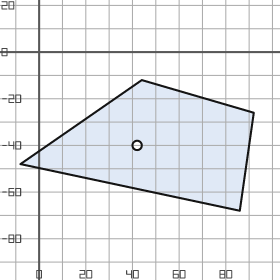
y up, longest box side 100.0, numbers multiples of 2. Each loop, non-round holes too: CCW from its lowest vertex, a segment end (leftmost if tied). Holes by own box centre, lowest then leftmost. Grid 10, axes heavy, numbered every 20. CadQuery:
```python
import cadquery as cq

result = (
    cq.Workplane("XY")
    .moveTo(86.0, -68.0)
    .lineTo(92.0, -26.0)
    .lineTo(44.0, -12.0)
    .lineTo(-8.0, -48.0)
    .close()
    .moveTo(42.0, -40.0)
    .circle(2.0)
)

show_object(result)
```